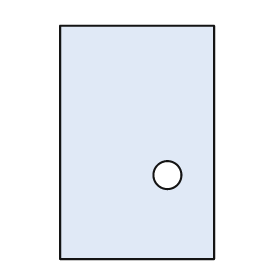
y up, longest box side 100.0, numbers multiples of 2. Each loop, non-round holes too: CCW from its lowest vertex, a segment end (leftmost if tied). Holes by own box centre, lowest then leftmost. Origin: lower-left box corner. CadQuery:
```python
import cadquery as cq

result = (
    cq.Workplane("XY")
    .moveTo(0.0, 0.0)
    .lineTo(66.0, 0.0)
    .lineTo(66.0, 100.0)
    .lineTo(0.0, 100.0)
    .close()
    .moveTo(46.0, 36.0)
    .circle(6.0)
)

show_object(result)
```